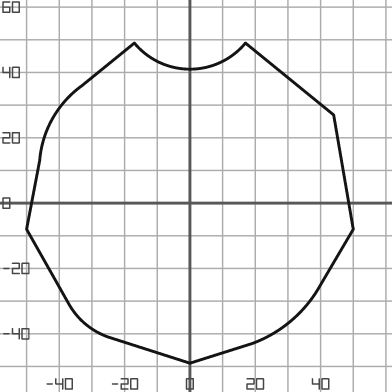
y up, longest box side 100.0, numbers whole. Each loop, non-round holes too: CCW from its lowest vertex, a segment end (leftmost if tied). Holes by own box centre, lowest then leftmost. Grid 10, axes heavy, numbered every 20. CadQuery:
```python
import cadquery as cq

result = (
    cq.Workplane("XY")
    .moveTo(0.0, -49.0)
    .lineTo(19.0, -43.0)
    .threePointArc((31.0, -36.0), (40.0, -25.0))
    .lineTo(50.0, -8.0)
    .lineTo(44.0, 27.0)
    .lineTo(17.0, 49.0)
    .threePointArc((0.0, 41.0), (-17.0, 49.0))
    .lineTo(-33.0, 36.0)
    .threePointArc((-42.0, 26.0), (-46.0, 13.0))
    .lineTo(-50.0, -8.0)
    .lineTo(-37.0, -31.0)
    .threePointArc((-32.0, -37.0), (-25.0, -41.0))
    .close()
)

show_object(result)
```